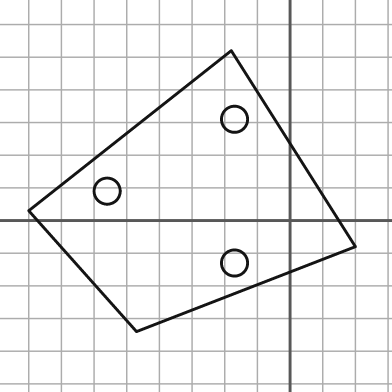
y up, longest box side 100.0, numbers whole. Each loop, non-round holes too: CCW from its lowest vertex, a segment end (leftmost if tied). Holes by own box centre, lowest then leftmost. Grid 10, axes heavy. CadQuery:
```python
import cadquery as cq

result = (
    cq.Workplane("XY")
    .moveTo(-47.0, -34.0)
    .lineTo(20.0, -8.0)
    .lineTo(-18.0, 52.0)
    .lineTo(-80.0, 3.0)
    .close()
    .moveTo(-17.0, -13.0)
    .circle(4.0)
    .moveTo(-56.0, 9.0)
    .circle(4.0)
    .moveTo(-17.0, 31.0)
    .circle(4.0)
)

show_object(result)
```